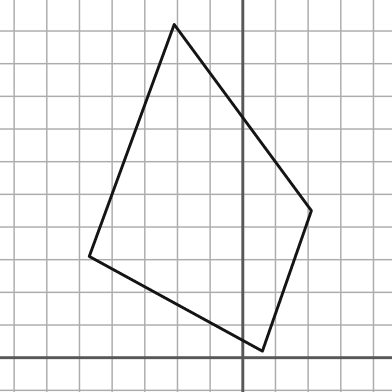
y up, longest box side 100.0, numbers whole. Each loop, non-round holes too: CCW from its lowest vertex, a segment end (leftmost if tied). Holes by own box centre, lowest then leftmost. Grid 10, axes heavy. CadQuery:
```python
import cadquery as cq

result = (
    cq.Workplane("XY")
    .moveTo(6.0, 2.0)
    .lineTo(21.0, 45.0)
    .lineTo(-21.0, 102.0)
    .lineTo(-47.0, 31.0)
    .close()
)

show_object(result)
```